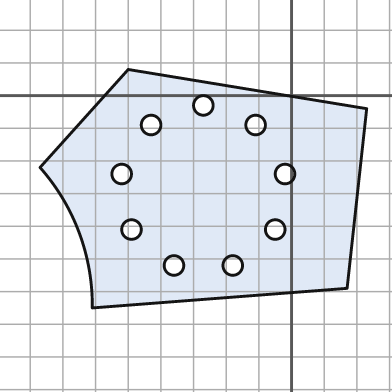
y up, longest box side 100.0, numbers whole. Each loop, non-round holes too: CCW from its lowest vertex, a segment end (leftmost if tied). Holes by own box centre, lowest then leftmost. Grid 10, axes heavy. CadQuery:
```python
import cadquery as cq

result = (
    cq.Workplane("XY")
    .moveTo(-61.0, -65.0)
    .lineTo(17.0, -59.0)
    .lineTo(23.0, -4.0)
    .lineTo(-50.0, 8.0)
    .lineTo(-77.0, -22.0)
    .threePointArc((-65.0, -42.0), (-61.0, -65.0))
    .close()
    .moveTo(-36.0, -52.0)
    .circle(3.0)
    .moveTo(-18.0, -52.0)
    .circle(3.0)
    .moveTo(-49.0, -41.0)
    .circle(3.0)
    .moveTo(-5.0, -41.0)
    .circle(3.0)
    .moveTo(-52.0, -24.0)
    .circle(3.0)
    .moveTo(-2.0, -24.0)
    .circle(3.0)
    .moveTo(-43.0, -9.0)
    .circle(3.0)
    .moveTo(-11.0, -9.0)
    .circle(3.0)
    .moveTo(-27.0, -3.0)
    .circle(3.0)
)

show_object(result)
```